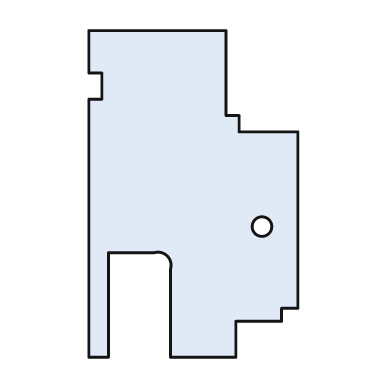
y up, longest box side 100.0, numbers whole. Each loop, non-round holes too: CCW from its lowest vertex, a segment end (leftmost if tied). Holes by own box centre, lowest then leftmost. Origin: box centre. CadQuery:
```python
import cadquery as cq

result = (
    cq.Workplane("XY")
    .moveTo(-32.0, -50.0)
    .lineTo(-26.0, -50.0)
    .lineTo(-26.0, -18.0)
    .lineTo(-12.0, -18.0)
    .threePointArc((-8.0, -19.0), (-7.0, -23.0))
    .lineTo(-7.0, -50.0)
    .lineTo(13.0, -50.0)
    .lineTo(13.0, -39.0)
    .lineTo(27.0, -39.0)
    .lineTo(27.0, -35.0)
    .lineTo(32.0, -35.0)
    .lineTo(32.0, 19.0)
    .lineTo(14.0, 19.0)
    .lineTo(14.0, 24.0)
    .lineTo(10.0, 24.0)
    .lineTo(10.0, 50.0)
    .lineTo(-32.0, 50.0)
    .lineTo(-32.0, 37.0)
    .lineTo(-28.0, 37.0)
    .lineTo(-28.0, 29.0)
    .lineTo(-32.0, 29.0)
    .close()
    .moveTo(21.0, -10.0)
    .circle(3.0)
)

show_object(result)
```